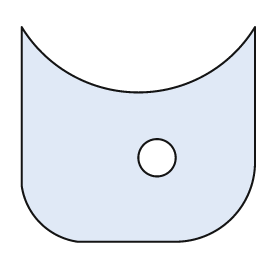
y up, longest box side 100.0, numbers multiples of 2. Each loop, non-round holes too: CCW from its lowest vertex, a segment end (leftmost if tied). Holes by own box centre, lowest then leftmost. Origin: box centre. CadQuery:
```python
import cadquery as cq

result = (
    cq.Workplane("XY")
    .moveTo(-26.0, -46.0)
    .lineTo(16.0, -46.0)
    .threePointArc((40.0, -36.0), (50.0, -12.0))
    .lineTo(50.0, 46.0)
    .threePointArc((0.0, 18.0), (-50.0, 46.0))
    .lineTo(-50.0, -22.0)
    .threePointArc((-42.0, -38.0), (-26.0, -46.0))
    .close()
    .moveTo(8.0, -10.0)
    .circle(8.0)
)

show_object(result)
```